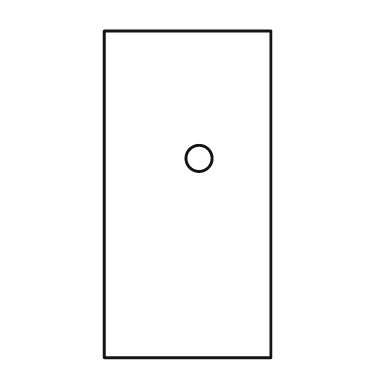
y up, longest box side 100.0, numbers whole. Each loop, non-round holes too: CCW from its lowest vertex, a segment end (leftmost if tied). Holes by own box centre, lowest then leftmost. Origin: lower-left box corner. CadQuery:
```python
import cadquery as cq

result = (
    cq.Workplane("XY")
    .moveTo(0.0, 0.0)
    .lineTo(51.0, 0.0)
    .lineTo(51.0, 100.0)
    .lineTo(0.0, 100.0)
    .close()
    .moveTo(29.0, 61.0)
    .circle(4.0)
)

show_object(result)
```